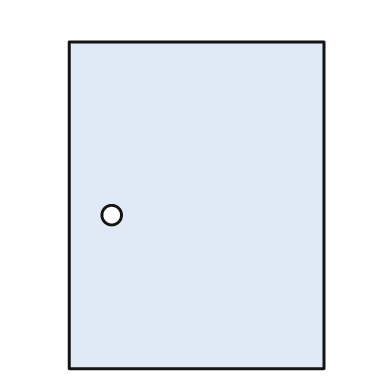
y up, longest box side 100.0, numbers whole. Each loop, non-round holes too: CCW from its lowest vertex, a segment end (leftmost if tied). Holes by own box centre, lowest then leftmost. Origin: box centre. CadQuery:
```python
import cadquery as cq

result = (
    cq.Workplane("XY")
    .moveTo(-39.0, -50.0)
    .lineTo(39.0, -50.0)
    .lineTo(39.0, 50.0)
    .lineTo(-39.0, 50.0)
    .close()
    .moveTo(-26.0, -3.0)
    .circle(3.0)
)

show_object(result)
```